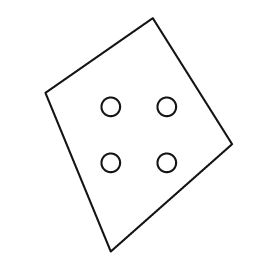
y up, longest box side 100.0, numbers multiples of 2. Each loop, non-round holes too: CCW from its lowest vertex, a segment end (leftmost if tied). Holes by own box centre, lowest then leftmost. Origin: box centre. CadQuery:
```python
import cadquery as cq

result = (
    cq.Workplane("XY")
    .moveTo(-12.0, -50.0)
    .lineTo(40.0, -4.0)
    .lineTo(6.0, 50.0)
    .lineTo(-40.0, 18.0)
    .close()
    .moveTo(-12.0, -12.0)
    .circle(4.0)
    .moveTo(12.0, -12.0)
    .circle(4.0)
    .moveTo(-12.0, 12.0)
    .circle(4.0)
    .moveTo(12.0, 12.0)
    .circle(4.0)
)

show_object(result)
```